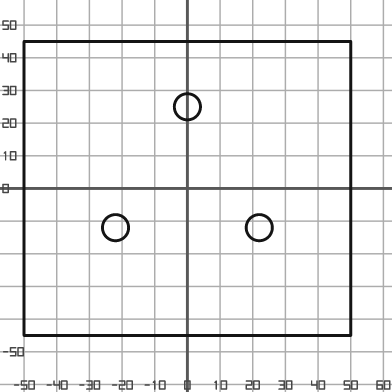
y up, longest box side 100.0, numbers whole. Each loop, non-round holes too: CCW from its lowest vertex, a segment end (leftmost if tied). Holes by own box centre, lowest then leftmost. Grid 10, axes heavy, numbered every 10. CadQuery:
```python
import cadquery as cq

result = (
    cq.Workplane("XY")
    .moveTo(-50.0, -45.0)
    .lineTo(50.0, -45.0)
    .lineTo(50.0, 45.0)
    .lineTo(-50.0, 45.0)
    .close()
    .moveTo(-22.0, -12.0)
    .circle(4.0)
    .moveTo(22.0, -12.0)
    .circle(4.0)
    .moveTo(0.0, 25.0)
    .circle(4.0)
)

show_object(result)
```